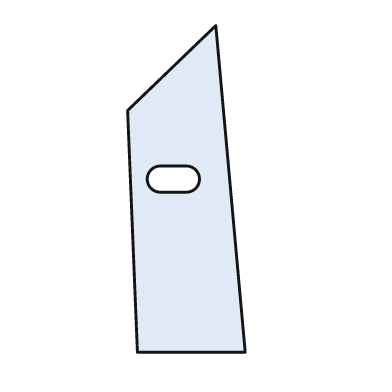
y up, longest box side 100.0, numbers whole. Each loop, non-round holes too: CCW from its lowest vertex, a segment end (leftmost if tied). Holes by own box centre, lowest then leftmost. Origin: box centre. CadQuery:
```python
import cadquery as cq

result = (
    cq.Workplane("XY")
    .moveTo(-15.0, -50.0)
    .lineTo(18.0, -50.0)
    .lineTo(9.0, 50.0)
    .lineTo(-18.0, 24.0)
    .close()
    .moveTo(-8.0, -1.0)
    .lineTo(0.0, -1.0)
    .threePointArc((4.0, 3.0), (0.0, 7.0))
    .lineTo(-8.0, 7.0)
    .threePointArc((-12.0, 3.0), (-8.0, -1.0))
    .close()
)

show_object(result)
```